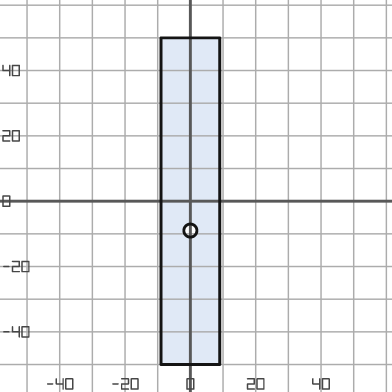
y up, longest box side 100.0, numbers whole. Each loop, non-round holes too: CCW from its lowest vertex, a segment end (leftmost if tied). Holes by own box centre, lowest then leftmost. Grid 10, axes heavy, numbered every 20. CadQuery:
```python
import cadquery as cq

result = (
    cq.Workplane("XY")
    .moveTo(-9.0, -50.0)
    .lineTo(9.0, -50.0)
    .lineTo(9.0, 50.0)
    .lineTo(-9.0, 50.0)
    .close()
    .moveTo(0.0, -9.0)
    .circle(2.0)
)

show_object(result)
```